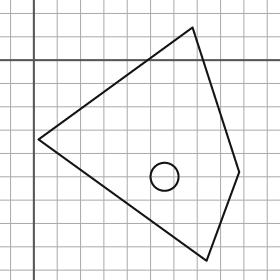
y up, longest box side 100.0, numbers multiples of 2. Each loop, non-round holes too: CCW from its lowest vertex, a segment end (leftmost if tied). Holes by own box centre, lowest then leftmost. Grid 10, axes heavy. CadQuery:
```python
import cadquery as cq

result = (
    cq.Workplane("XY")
    .moveTo(74.0, -86.0)
    .lineTo(88.0, -48.0)
    .lineTo(68.0, 14.0)
    .lineTo(2.0, -34.0)
    .close()
    .moveTo(56.0, -50.0)
    .circle(6.0)
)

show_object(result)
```